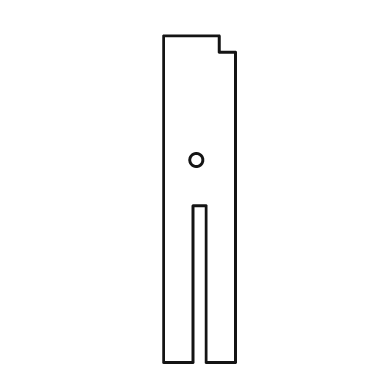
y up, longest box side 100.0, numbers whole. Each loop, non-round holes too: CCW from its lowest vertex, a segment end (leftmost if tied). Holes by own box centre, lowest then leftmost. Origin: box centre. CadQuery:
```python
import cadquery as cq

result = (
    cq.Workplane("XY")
    .moveTo(-11.0, -50.0)
    .lineTo(-2.0, -50.0)
    .lineTo(-2.0, -2.0)
    .lineTo(2.0, -2.0)
    .lineTo(2.0, -50.0)
    .lineTo(11.0, -50.0)
    .lineTo(11.0, 45.0)
    .lineTo(6.0, 45.0)
    .lineTo(6.0, 50.0)
    .lineTo(-11.0, 50.0)
    .close()
    .moveTo(-1.0, 12.0)
    .circle(2.0)
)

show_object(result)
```